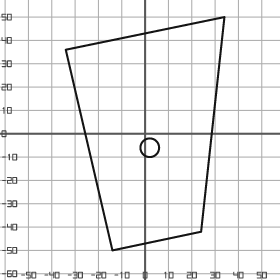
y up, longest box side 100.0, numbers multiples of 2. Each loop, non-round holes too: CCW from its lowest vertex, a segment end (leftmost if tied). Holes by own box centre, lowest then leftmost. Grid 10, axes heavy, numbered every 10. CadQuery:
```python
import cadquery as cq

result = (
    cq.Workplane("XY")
    .moveTo(-14.0, -50.0)
    .lineTo(24.0, -42.0)
    .lineTo(34.0, 50.0)
    .lineTo(-34.0, 36.0)
    .close()
    .moveTo(2.0, -6.0)
    .circle(4.0)
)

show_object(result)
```